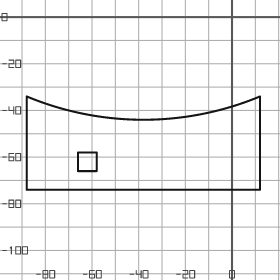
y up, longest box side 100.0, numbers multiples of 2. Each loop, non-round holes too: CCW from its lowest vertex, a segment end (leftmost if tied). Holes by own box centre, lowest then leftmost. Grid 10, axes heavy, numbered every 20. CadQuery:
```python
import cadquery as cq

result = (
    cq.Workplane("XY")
    .moveTo(-88.0, -74.0)
    .lineTo(12.0, -74.0)
    .lineTo(12.0, -34.0)
    .threePointArc((-38.0, -44.0), (-88.0, -34.0))
    .close()
    .moveTo(-66.0, -66.0)
    .lineTo(-58.0, -66.0)
    .lineTo(-58.0, -58.0)
    .lineTo(-66.0, -58.0)
    .close()
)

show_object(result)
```